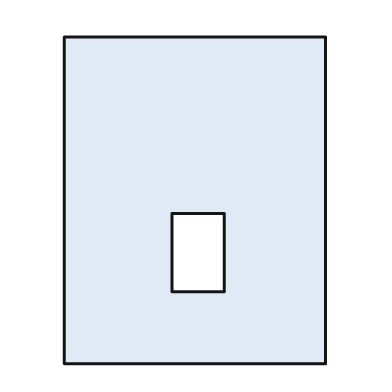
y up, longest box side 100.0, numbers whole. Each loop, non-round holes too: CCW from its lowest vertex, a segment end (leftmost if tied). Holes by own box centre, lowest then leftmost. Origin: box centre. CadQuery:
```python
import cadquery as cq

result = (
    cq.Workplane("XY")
    .moveTo(-40.0, -50.0)
    .lineTo(40.0, -50.0)
    .lineTo(40.0, 50.0)
    .lineTo(-40.0, 50.0)
    .close()
    .moveTo(-7.0, -28.0)
    .lineTo(9.0, -28.0)
    .lineTo(9.0, -4.0)
    .lineTo(-7.0, -4.0)
    .close()
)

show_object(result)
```